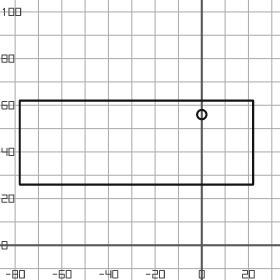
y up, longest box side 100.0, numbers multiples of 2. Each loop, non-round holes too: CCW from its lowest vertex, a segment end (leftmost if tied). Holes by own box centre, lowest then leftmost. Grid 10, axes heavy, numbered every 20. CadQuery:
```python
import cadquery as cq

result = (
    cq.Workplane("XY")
    .moveTo(-78.0, 26.0)
    .lineTo(22.0, 26.0)
    .lineTo(22.0, 62.0)
    .lineTo(-78.0, 62.0)
    .close()
    .moveTo(0.0, 56.0)
    .circle(2.0)
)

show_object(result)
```